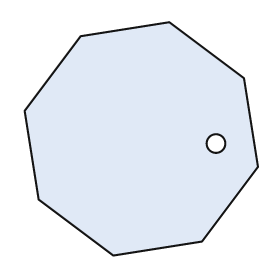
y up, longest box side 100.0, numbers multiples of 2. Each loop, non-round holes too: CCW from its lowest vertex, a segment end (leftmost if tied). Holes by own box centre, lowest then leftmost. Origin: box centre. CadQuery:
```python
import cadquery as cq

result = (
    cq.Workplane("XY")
    .moveTo(-12.0, -50.0)
    .lineTo(26.0, -44.0)
    .lineTo(50.0, -12.0)
    .lineTo(44.0, 26.0)
    .lineTo(12.0, 50.0)
    .lineTo(-26.0, 44.0)
    .lineTo(-50.0, 12.0)
    .lineTo(-44.0, -26.0)
    .close()
    .moveTo(32.0, -2.0)
    .circle(4.0)
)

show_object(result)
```